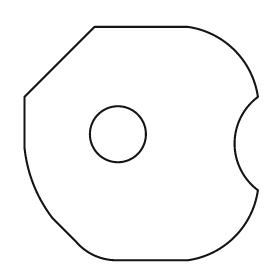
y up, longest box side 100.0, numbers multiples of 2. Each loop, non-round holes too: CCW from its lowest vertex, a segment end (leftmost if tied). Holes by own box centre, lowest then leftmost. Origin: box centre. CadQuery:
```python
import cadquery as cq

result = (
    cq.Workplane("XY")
    .moveTo(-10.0, -50.0)
    .lineTo(20.0, -50.0)
    .threePointArc((40.0, -40.0), (50.0, -20.0))
    .threePointArc((40.0, 0.0), (50.0, 20.0))
    .threePointArc((40.0, 40.0), (20.0, 50.0))
    .lineTo(-20.0, 50.0)
    .lineTo(-50.0, 20.0)
    .lineTo(-50.0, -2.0)
    .threePointArc((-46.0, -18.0), (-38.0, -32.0))
    .lineTo(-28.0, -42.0)
    .threePointArc((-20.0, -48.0), (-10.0, -50.0))
    .close()
    .moveTo(-10.0, 4.0)
    .circle(12.0)
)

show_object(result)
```